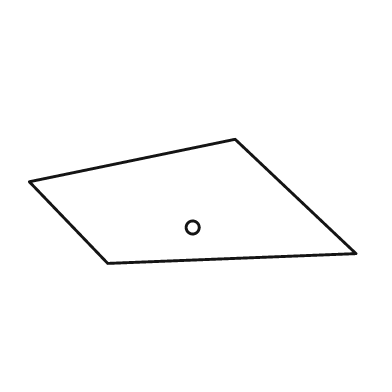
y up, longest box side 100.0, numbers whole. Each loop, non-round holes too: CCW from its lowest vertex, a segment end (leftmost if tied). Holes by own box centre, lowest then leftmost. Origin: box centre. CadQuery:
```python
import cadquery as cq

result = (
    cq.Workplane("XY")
    .moveTo(-26.0, -19.0)
    .lineTo(50.0, -16.0)
    .lineTo(13.0, 19.0)
    .lineTo(-50.0, 6.0)
    .close()
    .moveTo(0.0, -8.0)
    .circle(2.0)
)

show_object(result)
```